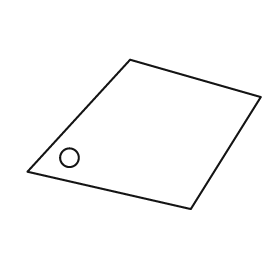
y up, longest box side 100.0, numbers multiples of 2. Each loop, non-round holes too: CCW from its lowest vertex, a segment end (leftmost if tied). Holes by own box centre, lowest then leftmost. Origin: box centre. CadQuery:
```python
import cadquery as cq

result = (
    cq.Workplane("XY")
    .moveTo(20.0, -32.0)
    .lineTo(50.0, 16.0)
    .lineTo(-6.0, 32.0)
    .lineTo(-50.0, -16.0)
    .close()
    .moveTo(-32.0, -10.0)
    .circle(4.0)
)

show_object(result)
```